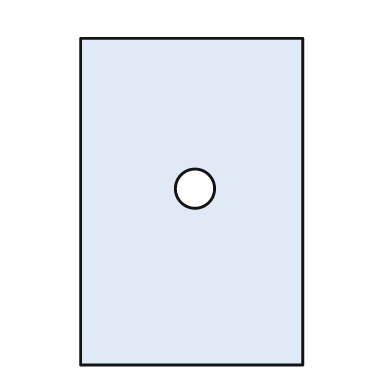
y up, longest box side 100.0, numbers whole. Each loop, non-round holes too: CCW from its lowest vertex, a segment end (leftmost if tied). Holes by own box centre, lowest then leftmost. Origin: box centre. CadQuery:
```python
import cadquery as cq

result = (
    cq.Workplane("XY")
    .moveTo(-34.0, -50.0)
    .lineTo(34.0, -50.0)
    .lineTo(34.0, 50.0)
    .lineTo(-34.0, 50.0)
    .close()
    .moveTo(1.0, 4.0)
    .circle(6.0)
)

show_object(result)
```